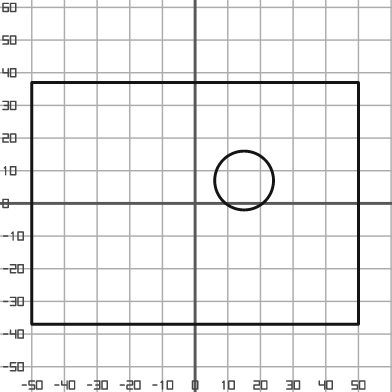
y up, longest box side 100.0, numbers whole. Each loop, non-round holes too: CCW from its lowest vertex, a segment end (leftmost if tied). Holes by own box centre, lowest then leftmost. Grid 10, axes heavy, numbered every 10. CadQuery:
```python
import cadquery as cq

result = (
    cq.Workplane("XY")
    .moveTo(-50.0, -37.0)
    .lineTo(50.0, -37.0)
    .lineTo(50.0, 37.0)
    .lineTo(-50.0, 37.0)
    .close()
    .moveTo(15.0, 7.0)
    .circle(9.0)
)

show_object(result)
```